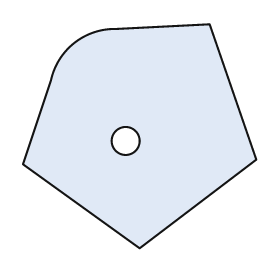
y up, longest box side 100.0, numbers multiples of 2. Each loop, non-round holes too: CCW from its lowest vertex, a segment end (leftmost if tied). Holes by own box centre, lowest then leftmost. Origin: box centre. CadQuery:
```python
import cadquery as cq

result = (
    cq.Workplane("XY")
    .moveTo(0.0, -48.0)
    .lineTo(50.0, -10.0)
    .lineTo(30.0, 48.0)
    .lineTo(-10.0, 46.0)
    .threePointArc((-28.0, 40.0), (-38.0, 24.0))
    .lineTo(-50.0, -12.0)
    .close()
    .moveTo(-6.0, -2.0)
    .circle(6.0)
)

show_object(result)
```